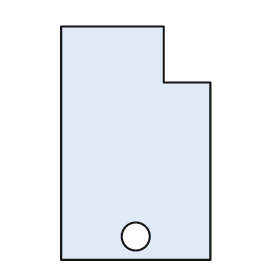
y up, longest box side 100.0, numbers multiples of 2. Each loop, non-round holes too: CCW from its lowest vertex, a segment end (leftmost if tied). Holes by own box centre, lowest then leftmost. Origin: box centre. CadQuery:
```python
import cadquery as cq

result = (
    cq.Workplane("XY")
    .moveTo(-32.0, -50.0)
    .lineTo(32.0, -50.0)
    .lineTo(32.0, 26.0)
    .lineTo(12.0, 26.0)
    .lineTo(12.0, 50.0)
    .lineTo(-32.0, 50.0)
    .close()
    .moveTo(0.0, -40.0)
    .circle(6.0)
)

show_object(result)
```